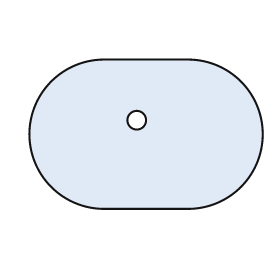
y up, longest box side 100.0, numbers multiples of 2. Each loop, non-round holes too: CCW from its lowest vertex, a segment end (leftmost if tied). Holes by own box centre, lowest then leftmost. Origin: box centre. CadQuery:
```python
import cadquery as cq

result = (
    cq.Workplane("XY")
    .moveTo(-18.0, -32.0)
    .lineTo(18.0, -32.0)
    .threePointArc((50.0, 0.0), (18.0, 32.0))
    .lineTo(-18.0, 32.0)
    .threePointArc((-50.0, 0.0), (-18.0, -32.0))
    .close()
    .moveTo(-4.0, 6.0)
    .circle(4.0)
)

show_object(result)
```